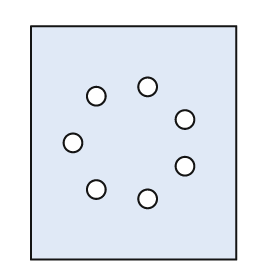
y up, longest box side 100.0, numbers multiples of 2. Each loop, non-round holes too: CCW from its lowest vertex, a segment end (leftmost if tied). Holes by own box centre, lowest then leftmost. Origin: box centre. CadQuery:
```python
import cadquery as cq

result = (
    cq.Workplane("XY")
    .moveTo(-44.0, -50.0)
    .lineTo(44.0, -50.0)
    .lineTo(44.0, 50.0)
    .lineTo(-44.0, 50.0)
    .close()
    .moveTo(6.0, -24.0)
    .circle(4.0)
    .moveTo(-16.0, -20.0)
    .circle(4.0)
    .moveTo(22.0, -10.0)
    .circle(4.0)
    .moveTo(-26.0, 0.0)
    .circle(4.0)
    .moveTo(22.0, 10.0)
    .circle(4.0)
    .moveTo(-16.0, 20.0)
    .circle(4.0)
    .moveTo(6.0, 24.0)
    .circle(4.0)
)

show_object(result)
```